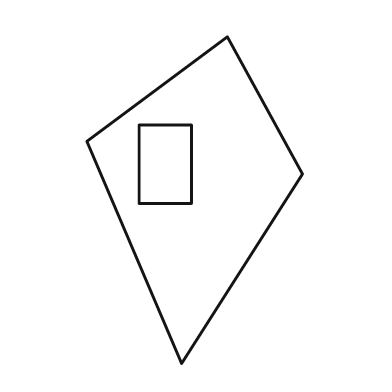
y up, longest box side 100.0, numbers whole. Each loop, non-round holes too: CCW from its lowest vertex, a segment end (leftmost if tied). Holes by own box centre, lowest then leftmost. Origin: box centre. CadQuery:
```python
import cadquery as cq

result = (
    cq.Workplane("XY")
    .moveTo(-4.0, -50.0)
    .lineTo(33.0, 8.0)
    .lineTo(10.0, 50.0)
    .lineTo(-33.0, 18.0)
    .close()
    .moveTo(-17.0, -1.0)
    .lineTo(-1.0, -1.0)
    .lineTo(-1.0, 23.0)
    .lineTo(-17.0, 23.0)
    .close()
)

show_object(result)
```